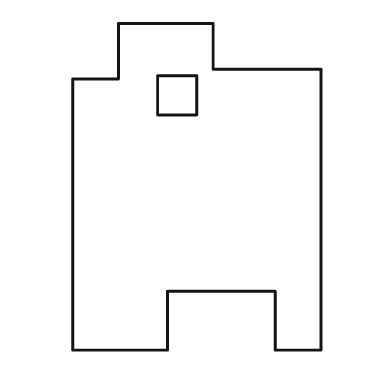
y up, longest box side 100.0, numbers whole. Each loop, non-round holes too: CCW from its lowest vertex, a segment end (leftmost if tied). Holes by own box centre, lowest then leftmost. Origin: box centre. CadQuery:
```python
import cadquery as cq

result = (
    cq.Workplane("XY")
    .moveTo(-38.0, -50.0)
    .lineTo(-9.0, -50.0)
    .lineTo(-9.0, -32.0)
    .lineTo(24.0, -32.0)
    .lineTo(24.0, -50.0)
    .lineTo(38.0, -50.0)
    .lineTo(38.0, 36.0)
    .lineTo(5.0, 36.0)
    .lineTo(5.0, 50.0)
    .lineTo(-24.0, 50.0)
    .lineTo(-24.0, 33.0)
    .lineTo(-38.0, 33.0)
    .close()
    .moveTo(-12.0, 22.0)
    .lineTo(0.0, 22.0)
    .lineTo(0.0, 34.0)
    .lineTo(-12.0, 34.0)
    .close()
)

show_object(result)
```